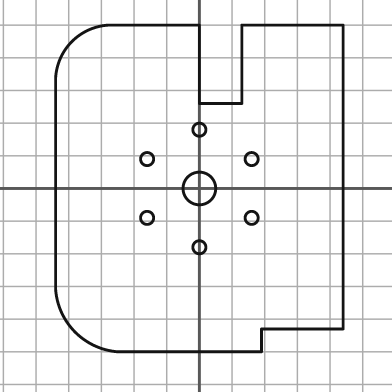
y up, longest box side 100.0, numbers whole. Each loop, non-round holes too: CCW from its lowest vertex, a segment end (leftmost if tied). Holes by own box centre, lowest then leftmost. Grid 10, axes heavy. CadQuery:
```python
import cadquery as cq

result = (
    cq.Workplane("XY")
    .moveTo(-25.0, -50.0)
    .lineTo(19.0, -50.0)
    .lineTo(19.0, -43.0)
    .lineTo(44.0, -43.0)
    .lineTo(44.0, 50.0)
    .lineTo(13.0, 50.0)
    .lineTo(13.0, 26.0)
    .lineTo(0.0, 26.0)
    .lineTo(0.0, 50.0)
    .lineTo(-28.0, 50.0)
    .threePointArc((-39.0, 45.0), (-44.0, 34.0))
    .lineTo(-44.0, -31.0)
    .threePointArc((-38.0, -44.0), (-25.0, -50.0))
    .close()
    .moveTo(0.0, -18.0)
    .circle(2.0)
    .moveTo(-16.0, -9.0)
    .circle(2.0)
    .moveTo(16.0, -9.0)
    .circle(2.0)
    .moveTo(0.0, 0.0)
    .circle(5.0)
    .moveTo(-16.0, 9.0)
    .circle(2.0)
    .moveTo(16.0, 9.0)
    .circle(2.0)
    .moveTo(0.0, 18.0)
    .circle(2.0)
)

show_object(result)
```